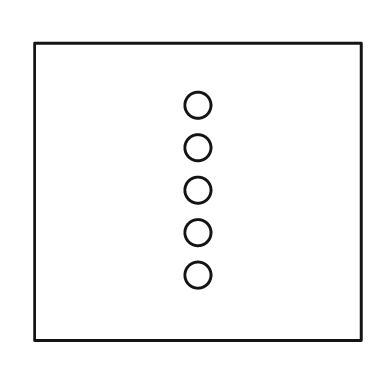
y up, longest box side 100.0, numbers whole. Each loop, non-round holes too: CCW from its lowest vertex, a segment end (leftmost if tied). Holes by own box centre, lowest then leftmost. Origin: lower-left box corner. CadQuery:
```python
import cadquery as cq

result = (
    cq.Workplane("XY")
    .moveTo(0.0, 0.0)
    .lineTo(100.0, 0.0)
    .lineTo(100.0, 91.0)
    .lineTo(0.0, 91.0)
    .close()
    .moveTo(50.0, 20.0)
    .circle(4.0)
    .moveTo(50.0, 33.0)
    .circle(4.0)
    .moveTo(50.0, 46.0)
    .circle(4.0)
    .moveTo(50.0, 59.0)
    .circle(4.0)
    .moveTo(50.0, 72.0)
    .circle(4.0)
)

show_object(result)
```